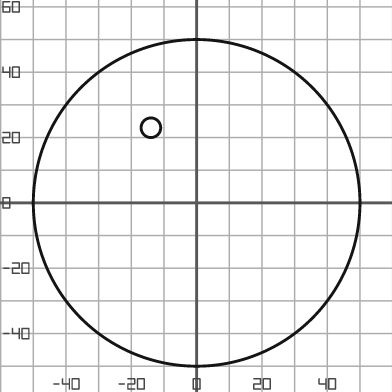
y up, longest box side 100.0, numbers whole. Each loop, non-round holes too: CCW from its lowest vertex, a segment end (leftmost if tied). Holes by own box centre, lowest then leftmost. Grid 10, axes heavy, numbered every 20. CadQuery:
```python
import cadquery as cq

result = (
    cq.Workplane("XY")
    .moveTo(0.0, 0.0)
    .circle(50.0)
    .moveTo(-14.0, 23.0)
    .circle(3.0)
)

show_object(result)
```